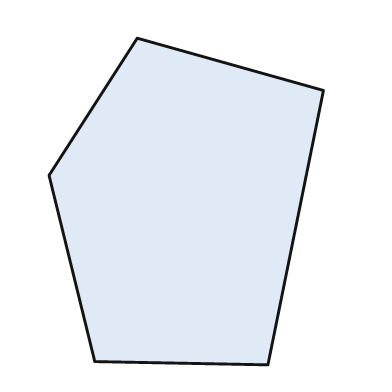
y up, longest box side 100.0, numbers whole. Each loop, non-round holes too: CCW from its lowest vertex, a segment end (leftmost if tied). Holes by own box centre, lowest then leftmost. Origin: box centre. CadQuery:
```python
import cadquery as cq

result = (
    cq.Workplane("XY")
    .moveTo(25.0, -50.0)
    .lineTo(42.0, 34.0)
    .lineTo(-15.0, 50.0)
    .lineTo(-42.0, 8.0)
    .lineTo(-28.0, -49.0)
    .close()
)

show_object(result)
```